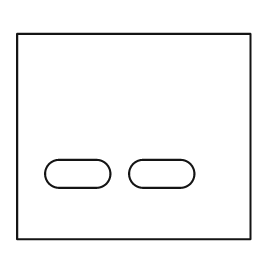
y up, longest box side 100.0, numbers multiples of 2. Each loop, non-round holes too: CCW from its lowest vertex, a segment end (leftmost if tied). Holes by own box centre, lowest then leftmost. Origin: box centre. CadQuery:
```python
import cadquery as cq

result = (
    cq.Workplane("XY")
    .moveTo(-50.0, -44.0)
    .lineTo(50.0, -44.0)
    .lineTo(50.0, 44.0)
    .lineTo(-50.0, 44.0)
    .close()
    .moveTo(-32.0, -22.0)
    .lineTo(-16.0, -22.0)
    .threePointArc((-10.0, -16.0), (-16.0, -10.0))
    .lineTo(-32.0, -10.0)
    .threePointArc((-38.0, -16.0), (-32.0, -22.0))
    .close()
    .moveTo(4.0, -22.0)
    .lineTo(20.0, -22.0)
    .threePointArc((26.0, -16.0), (20.0, -10.0))
    .lineTo(4.0, -10.0)
    .threePointArc((-2.0, -16.0), (4.0, -22.0))
    .close()
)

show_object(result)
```